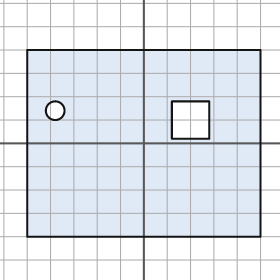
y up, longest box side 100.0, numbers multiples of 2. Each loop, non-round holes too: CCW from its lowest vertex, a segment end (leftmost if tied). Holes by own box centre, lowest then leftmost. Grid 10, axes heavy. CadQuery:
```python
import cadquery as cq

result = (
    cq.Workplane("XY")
    .moveTo(-50.0, -40.0)
    .lineTo(50.0, -40.0)
    .lineTo(50.0, 40.0)
    .lineTo(-50.0, 40.0)
    .close()
    .moveTo(12.0, 2.0)
    .lineTo(28.0, 2.0)
    .lineTo(28.0, 18.0)
    .lineTo(12.0, 18.0)
    .close()
    .moveTo(-38.0, 14.0)
    .circle(4.0)
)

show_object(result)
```